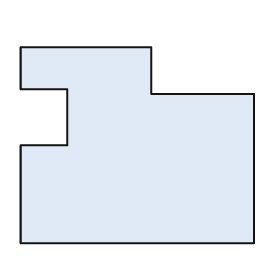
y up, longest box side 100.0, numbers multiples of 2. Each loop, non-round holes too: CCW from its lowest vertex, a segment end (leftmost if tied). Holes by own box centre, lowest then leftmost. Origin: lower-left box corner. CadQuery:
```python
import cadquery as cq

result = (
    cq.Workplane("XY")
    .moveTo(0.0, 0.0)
    .lineTo(100.0, 0.0)
    .lineTo(100.0, 64.0)
    .lineTo(56.0, 64.0)
    .lineTo(56.0, 84.0)
    .lineTo(0.0, 84.0)
    .lineTo(0.0, 66.0)
    .lineTo(20.0, 66.0)
    .lineTo(20.0, 42.0)
    .lineTo(0.0, 42.0)
    .close()
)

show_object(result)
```